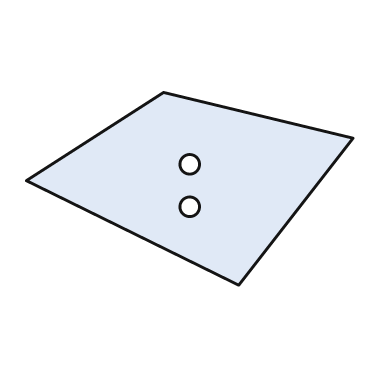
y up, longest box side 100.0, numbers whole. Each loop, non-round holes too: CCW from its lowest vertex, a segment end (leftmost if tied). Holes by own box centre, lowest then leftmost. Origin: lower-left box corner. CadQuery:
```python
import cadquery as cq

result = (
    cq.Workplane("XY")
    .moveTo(65.0, 0.0)
    .lineTo(100.0, 45.0)
    .lineTo(42.0, 59.0)
    .lineTo(0.0, 32.0)
    .close()
    .moveTo(50.0, 24.0)
    .circle(3.0)
    .moveTo(50.0, 37.0)
    .circle(3.0)
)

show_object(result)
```